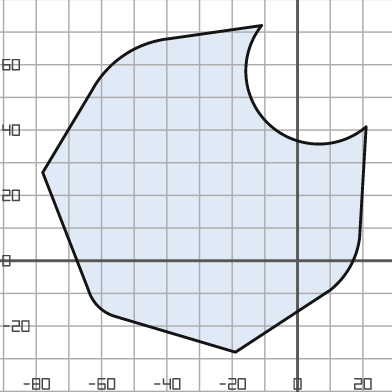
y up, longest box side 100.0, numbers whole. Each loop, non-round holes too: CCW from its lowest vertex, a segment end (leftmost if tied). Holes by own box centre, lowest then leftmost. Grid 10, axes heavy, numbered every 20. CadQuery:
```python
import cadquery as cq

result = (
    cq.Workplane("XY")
    .moveTo(-19.0, -28.0)
    .lineTo(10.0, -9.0)
    .threePointArc((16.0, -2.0), (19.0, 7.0))
    .lineTo(21.0, 41.0)
    .threePointArc((-9.0, 42.0), (-11.0, 72.0))
    .lineTo(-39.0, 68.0)
    .threePointArc((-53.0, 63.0), (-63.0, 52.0))
    .lineTo(-78.0, 27.0)
    .lineTo(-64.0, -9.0)
    .threePointArc((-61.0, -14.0), (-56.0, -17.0))
    .close()
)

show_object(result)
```